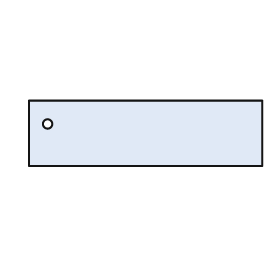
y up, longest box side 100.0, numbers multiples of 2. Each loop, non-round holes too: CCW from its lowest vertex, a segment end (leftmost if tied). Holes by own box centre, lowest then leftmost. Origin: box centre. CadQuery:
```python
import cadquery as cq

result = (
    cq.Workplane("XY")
    .moveTo(-50.0, -14.0)
    .lineTo(50.0, -14.0)
    .lineTo(50.0, 14.0)
    .lineTo(-50.0, 14.0)
    .close()
    .moveTo(-42.0, 4.0)
    .circle(2.0)
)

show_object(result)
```